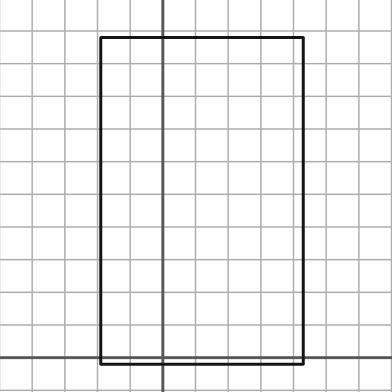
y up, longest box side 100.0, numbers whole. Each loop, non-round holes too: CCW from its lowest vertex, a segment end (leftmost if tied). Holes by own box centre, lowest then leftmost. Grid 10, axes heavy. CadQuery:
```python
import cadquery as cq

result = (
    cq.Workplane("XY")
    .moveTo(-19.0, -2.0)
    .lineTo(43.0, -2.0)
    .lineTo(43.0, 98.0)
    .lineTo(-19.0, 98.0)
    .close()
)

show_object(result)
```